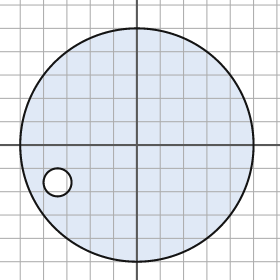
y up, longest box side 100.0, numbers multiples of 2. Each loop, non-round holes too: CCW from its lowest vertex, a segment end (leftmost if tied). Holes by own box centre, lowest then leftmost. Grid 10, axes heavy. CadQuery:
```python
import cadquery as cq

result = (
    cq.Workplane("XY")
    .moveTo(0.0, 0.0)
    .circle(50.0)
    .moveTo(-34.0, -16.0)
    .circle(6.0)
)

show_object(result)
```